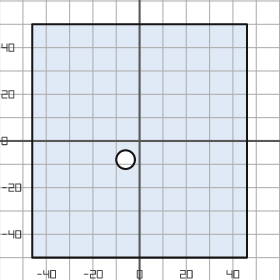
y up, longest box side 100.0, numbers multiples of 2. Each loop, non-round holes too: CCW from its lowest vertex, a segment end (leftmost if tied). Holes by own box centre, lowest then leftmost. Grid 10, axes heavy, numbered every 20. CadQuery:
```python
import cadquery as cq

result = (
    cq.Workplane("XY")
    .moveTo(-46.0, -50.0)
    .lineTo(46.0, -50.0)
    .lineTo(46.0, 50.0)
    .lineTo(-46.0, 50.0)
    .close()
    .moveTo(-6.0, -8.0)
    .circle(4.0)
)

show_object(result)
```